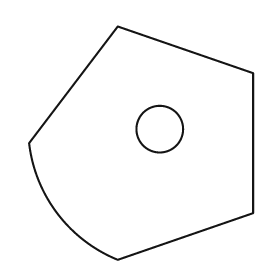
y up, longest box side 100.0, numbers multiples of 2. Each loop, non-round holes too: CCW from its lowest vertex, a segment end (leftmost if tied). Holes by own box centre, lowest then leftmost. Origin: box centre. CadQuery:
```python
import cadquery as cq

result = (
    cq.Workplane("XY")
    .moveTo(-10.0, -50.0)
    .lineTo(48.0, -30.0)
    .lineTo(48.0, 30.0)
    .lineTo(-10.0, 50.0)
    .lineTo(-48.0, 0.0)
    .threePointArc((-36.0, -30.0), (-10.0, -50.0))
    .close()
    .moveTo(8.0, 6.0)
    .circle(10.0)
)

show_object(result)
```